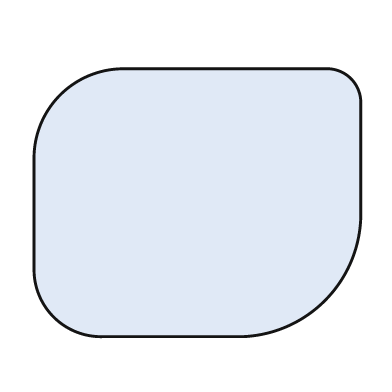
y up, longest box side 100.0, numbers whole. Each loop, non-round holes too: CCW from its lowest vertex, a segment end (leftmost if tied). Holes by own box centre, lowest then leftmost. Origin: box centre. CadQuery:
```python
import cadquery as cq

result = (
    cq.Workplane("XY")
    .moveTo(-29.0, -41.0)
    .lineTo(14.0, -41.0)
    .threePointArc((39.0, -30.0), (50.0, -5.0))
    .lineTo(50.0, 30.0)
    .threePointArc((47.0, 38.0), (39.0, 41.0))
    .lineTo(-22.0, 41.0)
    .threePointArc((-42.0, 33.0), (-50.0, 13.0))
    .lineTo(-50.0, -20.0)
    .threePointArc((-44.0, -35.0), (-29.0, -41.0))
    .close()
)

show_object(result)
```